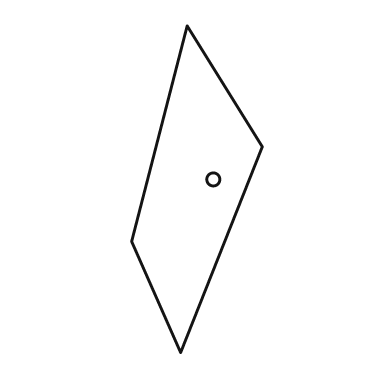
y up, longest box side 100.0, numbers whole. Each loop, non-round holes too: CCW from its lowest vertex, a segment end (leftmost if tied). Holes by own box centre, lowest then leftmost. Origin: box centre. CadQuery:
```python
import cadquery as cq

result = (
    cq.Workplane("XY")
    .moveTo(-5.0, -50.0)
    .lineTo(20.0, 13.0)
    .lineTo(-3.0, 50.0)
    .lineTo(-20.0, -16.0)
    .close()
    .moveTo(5.0, 3.0)
    .circle(2.0)
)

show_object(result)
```